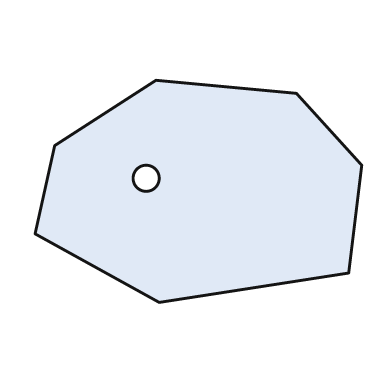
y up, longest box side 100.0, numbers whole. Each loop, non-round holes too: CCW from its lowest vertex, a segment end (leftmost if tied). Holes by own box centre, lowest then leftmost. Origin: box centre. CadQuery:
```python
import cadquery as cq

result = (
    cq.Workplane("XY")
    .moveTo(-12.0, -34.0)
    .lineTo(46.0, -25.0)
    .lineTo(50.0, 8.0)
    .lineTo(30.0, 30.0)
    .lineTo(-13.0, 34.0)
    .lineTo(-44.0, 14.0)
    .lineTo(-50.0, -13.0)
    .close()
    .moveTo(-16.0, 4.0)
    .circle(4.0)
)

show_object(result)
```